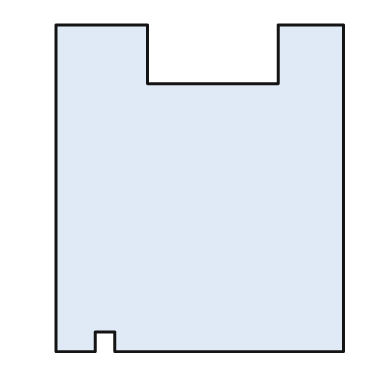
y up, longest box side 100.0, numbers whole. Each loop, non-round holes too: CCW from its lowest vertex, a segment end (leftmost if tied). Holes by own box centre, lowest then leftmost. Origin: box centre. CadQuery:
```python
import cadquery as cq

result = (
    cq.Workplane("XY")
    .moveTo(-44.0, -50.0)
    .lineTo(-32.0, -50.0)
    .lineTo(-32.0, -44.0)
    .lineTo(-26.0, -44.0)
    .lineTo(-26.0, -50.0)
    .lineTo(44.0, -50.0)
    .lineTo(44.0, 50.0)
    .lineTo(24.0, 50.0)
    .lineTo(24.0, 32.0)
    .lineTo(-16.0, 32.0)
    .lineTo(-16.0, 50.0)
    .lineTo(-44.0, 50.0)
    .close()
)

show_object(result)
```